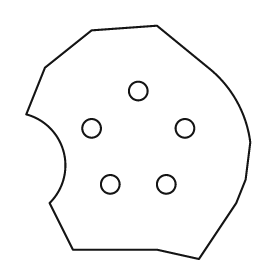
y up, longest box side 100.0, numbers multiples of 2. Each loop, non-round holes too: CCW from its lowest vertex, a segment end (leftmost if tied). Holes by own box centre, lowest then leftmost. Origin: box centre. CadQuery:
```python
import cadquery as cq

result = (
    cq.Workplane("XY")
    .moveTo(26.0, -50.0)
    .lineTo(42.0, -26.0)
    .lineTo(46.0, -16.0)
    .lineTo(48.0, 0.0)
    .threePointArc((42.0, 18.0), (30.0, 32.0))
    .lineTo(8.0, 50.0)
    .lineTo(-20.0, 48.0)
    .lineTo(-40.0, 32.0)
    .lineTo(-48.0, 12.0)
    .threePointArc((-32.0, -4.0), (-38.0, -26.0))
    .lineTo(-28.0, -46.0)
    .lineTo(8.0, -46.0)
    .close()
    .moveTo(-12.0, -18.0)
    .circle(4.0)
    .moveTo(12.0, -18.0)
    .circle(4.0)
    .moveTo(-20.0, 6.0)
    .circle(4.0)
    .moveTo(20.0, 6.0)
    .circle(4.0)
    .moveTo(0.0, 22.0)
    .circle(4.0)
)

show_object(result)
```